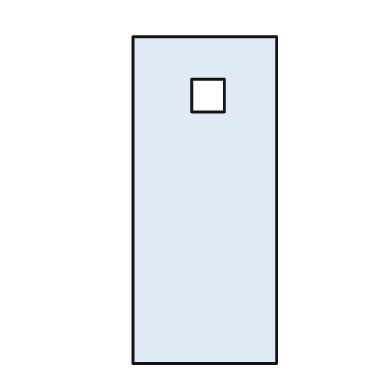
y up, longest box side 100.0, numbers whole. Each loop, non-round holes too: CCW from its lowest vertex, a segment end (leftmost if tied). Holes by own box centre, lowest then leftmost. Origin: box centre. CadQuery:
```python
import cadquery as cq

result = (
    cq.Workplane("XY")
    .moveTo(-22.0, -50.0)
    .lineTo(22.0, -50.0)
    .lineTo(22.0, 50.0)
    .lineTo(-22.0, 50.0)
    .close()
    .moveTo(-4.0, 27.0)
    .lineTo(6.0, 27.0)
    .lineTo(6.0, 37.0)
    .lineTo(-4.0, 37.0)
    .close()
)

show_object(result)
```